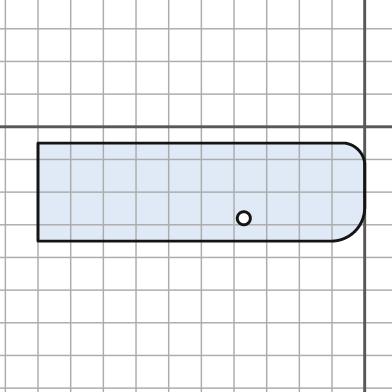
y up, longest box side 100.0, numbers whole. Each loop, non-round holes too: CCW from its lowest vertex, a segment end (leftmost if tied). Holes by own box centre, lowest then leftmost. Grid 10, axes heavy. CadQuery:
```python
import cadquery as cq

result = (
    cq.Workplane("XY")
    .moveTo(-100.0, -35.0)
    .lineTo(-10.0, -35.0)
    .threePointArc((-3.0, -32.0), (0.0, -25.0))
    .lineTo(0.0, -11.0)
    .threePointArc((-2.0, -7.0), (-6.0, -5.0))
    .lineTo(-100.0, -5.0)
    .close()
    .moveTo(-37.0, -28.0)
    .circle(2.0)
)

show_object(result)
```